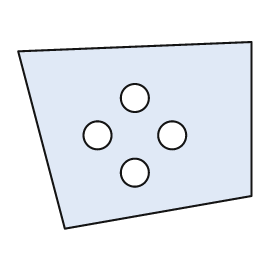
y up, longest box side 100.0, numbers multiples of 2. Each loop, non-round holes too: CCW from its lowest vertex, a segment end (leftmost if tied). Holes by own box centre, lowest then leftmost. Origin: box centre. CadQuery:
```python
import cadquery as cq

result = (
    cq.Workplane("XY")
    .moveTo(-30.0, -40.0)
    .lineTo(50.0, -26.0)
    .lineTo(50.0, 40.0)
    .lineTo(-50.0, 36.0)
    .close()
    .moveTo(0.0, -16.0)
    .circle(6.0)
    .moveTo(-16.0, 0.0)
    .circle(6.0)
    .moveTo(16.0, 0.0)
    .circle(6.0)
    .moveTo(0.0, 16.0)
    .circle(6.0)
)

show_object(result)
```